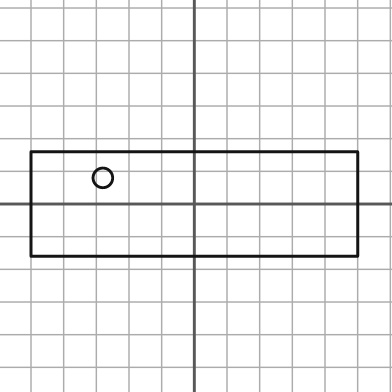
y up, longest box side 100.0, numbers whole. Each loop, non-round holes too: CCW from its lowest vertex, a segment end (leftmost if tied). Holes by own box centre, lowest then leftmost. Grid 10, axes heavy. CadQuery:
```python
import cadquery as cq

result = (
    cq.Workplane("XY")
    .moveTo(-50.0, -16.0)
    .lineTo(50.0, -16.0)
    .lineTo(50.0, 16.0)
    .lineTo(-50.0, 16.0)
    .close()
    .moveTo(-28.0, 8.0)
    .circle(3.0)
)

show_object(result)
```